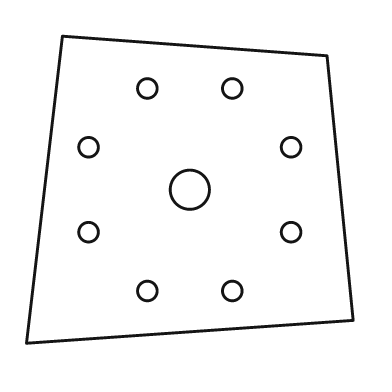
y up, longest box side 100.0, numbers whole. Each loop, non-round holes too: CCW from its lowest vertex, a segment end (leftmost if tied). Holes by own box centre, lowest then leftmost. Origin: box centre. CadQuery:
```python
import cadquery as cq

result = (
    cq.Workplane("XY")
    .moveTo(-50.0, -47.0)
    .lineTo(50.0, -40.0)
    .lineTo(42.0, 41.0)
    .lineTo(-39.0, 47.0)
    .close()
    .moveTo(-13.0, -31.0)
    .circle(3.0)
    .moveTo(13.0, -31.0)
    .circle(3.0)
    .moveTo(-31.0, -13.0)
    .circle(3.0)
    .moveTo(31.0, -13.0)
    .circle(3.0)
    .moveTo(0.0, 0.0)
    .circle(6.0)
    .moveTo(-31.0, 13.0)
    .circle(3.0)
    .moveTo(31.0, 13.0)
    .circle(3.0)
    .moveTo(-13.0, 31.0)
    .circle(3.0)
    .moveTo(13.0, 31.0)
    .circle(3.0)
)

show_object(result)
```